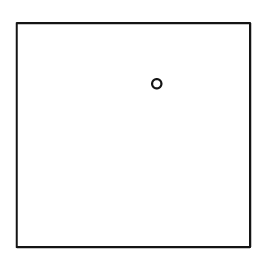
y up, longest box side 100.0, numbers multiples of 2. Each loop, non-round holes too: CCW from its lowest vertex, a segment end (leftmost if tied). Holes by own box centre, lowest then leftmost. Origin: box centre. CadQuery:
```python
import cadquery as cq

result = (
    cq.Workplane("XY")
    .moveTo(-50.0, -48.0)
    .lineTo(50.0, -48.0)
    .lineTo(50.0, 48.0)
    .lineTo(-50.0, 48.0)
    .close()
    .moveTo(10.0, 22.0)
    .circle(2.0)
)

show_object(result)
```